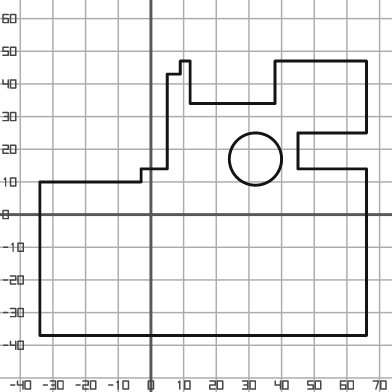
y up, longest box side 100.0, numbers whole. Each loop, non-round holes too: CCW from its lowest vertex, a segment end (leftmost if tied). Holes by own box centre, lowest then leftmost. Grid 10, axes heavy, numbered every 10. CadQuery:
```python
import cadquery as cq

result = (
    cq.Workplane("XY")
    .moveTo(-34.0, -37.0)
    .lineTo(66.0, -37.0)
    .lineTo(66.0, 14.0)
    .lineTo(45.0, 14.0)
    .lineTo(45.0, 25.0)
    .lineTo(66.0, 25.0)
    .lineTo(66.0, 47.0)
    .lineTo(38.0, 47.0)
    .lineTo(38.0, 34.0)
    .lineTo(12.0, 34.0)
    .lineTo(12.0, 47.0)
    .lineTo(9.0, 47.0)
    .lineTo(9.0, 43.0)
    .lineTo(5.0, 43.0)
    .lineTo(5.0, 14.0)
    .lineTo(-3.0, 14.0)
    .lineTo(-3.0, 10.0)
    .lineTo(-34.0, 10.0)
    .close()
    .moveTo(32.0, 17.0)
    .circle(8.0)
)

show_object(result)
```